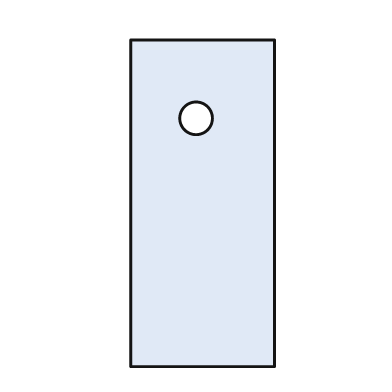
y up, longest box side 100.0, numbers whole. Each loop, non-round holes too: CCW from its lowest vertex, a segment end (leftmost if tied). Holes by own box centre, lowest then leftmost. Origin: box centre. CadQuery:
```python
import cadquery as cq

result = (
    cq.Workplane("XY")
    .moveTo(-22.0, -50.0)
    .lineTo(22.0, -50.0)
    .lineTo(22.0, 50.0)
    .lineTo(-22.0, 50.0)
    .close()
    .moveTo(-2.0, 26.0)
    .circle(5.0)
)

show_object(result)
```